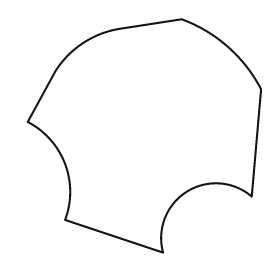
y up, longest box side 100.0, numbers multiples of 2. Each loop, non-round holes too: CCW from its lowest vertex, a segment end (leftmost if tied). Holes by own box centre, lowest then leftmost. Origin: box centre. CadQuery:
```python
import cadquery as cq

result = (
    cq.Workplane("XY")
    .moveTo(8.0, -50.0)
    .threePointArc((18.0, -24.0), (46.0, -26.0))
    .lineTo(50.0, 20.0)
    .threePointArc((36.0, 38.0), (16.0, 50.0))
    .lineTo(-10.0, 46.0)
    .threePointArc((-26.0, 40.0), (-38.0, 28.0))
    .lineTo(-50.0, 6.0)
    .threePointArc((-34.0, -12.0), (-34.0, -36.0))
    .close()
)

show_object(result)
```